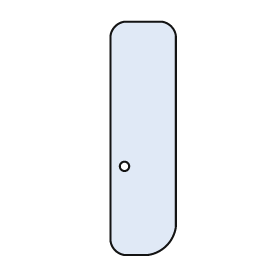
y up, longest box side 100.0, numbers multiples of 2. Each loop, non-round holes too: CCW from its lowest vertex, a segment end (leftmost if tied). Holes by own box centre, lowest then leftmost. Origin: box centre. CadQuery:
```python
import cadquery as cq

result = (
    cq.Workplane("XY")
    .moveTo(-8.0, -50.0)
    .lineTo(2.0, -50.0)
    .threePointArc((10.0, -46.0), (14.0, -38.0))
    .lineTo(14.0, 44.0)
    .threePointArc((12.0, 48.0), (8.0, 50.0))
    .lineTo(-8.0, 50.0)
    .threePointArc((-12.0, 48.0), (-14.0, 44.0))
    .lineTo(-14.0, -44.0)
    .threePointArc((-12.0, -48.0), (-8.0, -50.0))
    .close()
    .moveTo(-8.0, -12.0)
    .circle(2.0)
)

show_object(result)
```